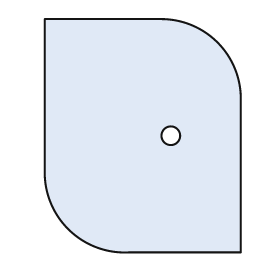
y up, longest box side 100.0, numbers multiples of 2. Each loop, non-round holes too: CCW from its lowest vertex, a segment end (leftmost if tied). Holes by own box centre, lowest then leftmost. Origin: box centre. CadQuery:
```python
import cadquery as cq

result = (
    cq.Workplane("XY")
    .moveTo(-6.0, -50.0)
    .lineTo(42.0, -50.0)
    .lineTo(42.0, 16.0)
    .threePointArc((32.0, 40.0), (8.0, 50.0))
    .lineTo(-42.0, 50.0)
    .lineTo(-42.0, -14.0)
    .threePointArc((-32.0, -40.0), (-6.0, -50.0))
    .close()
    .moveTo(12.0, 0.0)
    .circle(4.0)
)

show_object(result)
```